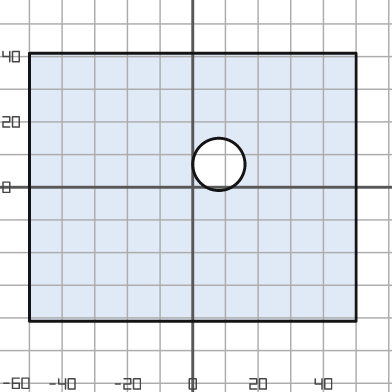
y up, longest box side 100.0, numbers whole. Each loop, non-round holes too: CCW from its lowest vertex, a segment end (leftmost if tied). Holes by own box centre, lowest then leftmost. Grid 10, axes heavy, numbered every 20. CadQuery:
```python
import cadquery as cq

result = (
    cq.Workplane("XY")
    .moveTo(-50.0, -41.0)
    .lineTo(50.0, -41.0)
    .lineTo(50.0, 41.0)
    .lineTo(-50.0, 41.0)
    .close()
    .moveTo(8.0, 7.0)
    .circle(8.0)
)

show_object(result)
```